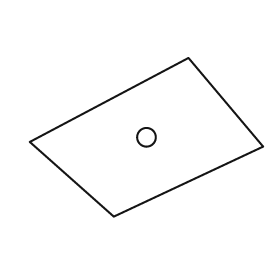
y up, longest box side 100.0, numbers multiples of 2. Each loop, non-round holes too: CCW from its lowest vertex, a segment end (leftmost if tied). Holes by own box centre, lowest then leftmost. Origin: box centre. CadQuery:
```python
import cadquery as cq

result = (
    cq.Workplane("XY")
    .moveTo(-14.0, -34.0)
    .lineTo(50.0, -4.0)
    .lineTo(18.0, 34.0)
    .lineTo(-50.0, -2.0)
    .close()
    .moveTo(0.0, 0.0)
    .circle(4.0)
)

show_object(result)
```